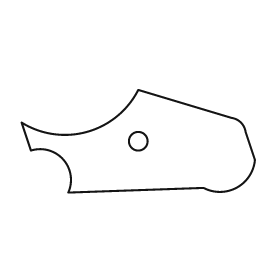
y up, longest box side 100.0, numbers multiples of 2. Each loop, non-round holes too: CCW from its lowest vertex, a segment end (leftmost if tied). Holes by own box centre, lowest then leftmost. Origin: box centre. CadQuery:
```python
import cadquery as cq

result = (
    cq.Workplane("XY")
    .moveTo(-30.0, -22.0)
    .lineTo(28.0, -20.0)
    .threePointArc((42.0, -20.0), (50.0, -8.0))
    .lineTo(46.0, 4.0)
    .threePointArc((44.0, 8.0), (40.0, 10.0))
    .lineTo(0.0, 22.0)
    .threePointArc((-22.0, 4.0), (-50.0, 8.0))
    .lineTo(-46.0, -4.0)
    .threePointArc((-32.0, -8.0), (-30.0, -22.0))
    .close()
    .moveTo(0.0, 0.0)
    .circle(4.0)
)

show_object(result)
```